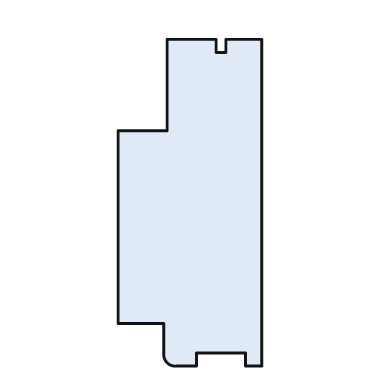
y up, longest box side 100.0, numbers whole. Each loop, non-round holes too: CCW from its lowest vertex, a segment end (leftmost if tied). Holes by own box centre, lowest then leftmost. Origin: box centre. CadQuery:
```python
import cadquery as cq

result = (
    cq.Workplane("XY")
    .moveTo(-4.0, -50.0)
    .lineTo(2.0, -50.0)
    .lineTo(2.0, -46.0)
    .lineTo(17.0, -46.0)
    .lineTo(17.0, -50.0)
    .lineTo(22.0, -50.0)
    .lineTo(22.0, 50.0)
    .lineTo(11.0, 50.0)
    .lineTo(11.0, 46.0)
    .lineTo(8.0, 46.0)
    .lineTo(8.0, 50.0)
    .lineTo(-7.0, 50.0)
    .lineTo(-7.0, 22.0)
    .lineTo(-22.0, 22.0)
    .lineTo(-22.0, -37.0)
    .lineTo(-8.0, -37.0)
    .lineTo(-8.0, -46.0)
    .threePointArc((-7.0, -49.0), (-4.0, -50.0))
    .close()
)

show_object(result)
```